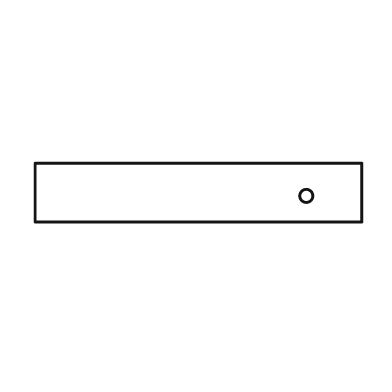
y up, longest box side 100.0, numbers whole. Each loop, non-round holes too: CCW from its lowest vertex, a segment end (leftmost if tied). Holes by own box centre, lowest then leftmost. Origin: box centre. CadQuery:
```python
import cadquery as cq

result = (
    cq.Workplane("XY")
    .moveTo(-50.0, -9.0)
    .lineTo(50.0, -9.0)
    .lineTo(50.0, 9.0)
    .lineTo(-50.0, 9.0)
    .close()
    .moveTo(33.0, -1.0)
    .circle(2.0)
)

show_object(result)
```